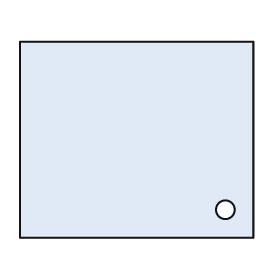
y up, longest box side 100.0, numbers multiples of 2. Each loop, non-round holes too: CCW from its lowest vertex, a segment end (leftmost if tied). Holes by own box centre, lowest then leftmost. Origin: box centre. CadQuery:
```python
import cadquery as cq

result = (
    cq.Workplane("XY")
    .moveTo(-50.0, -42.0)
    .lineTo(50.0, -42.0)
    .lineTo(50.0, 42.0)
    .lineTo(-50.0, 42.0)
    .close()
    .moveTo(38.0, -30.0)
    .circle(4.0)
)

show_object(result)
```